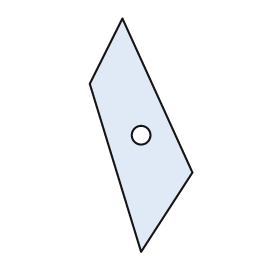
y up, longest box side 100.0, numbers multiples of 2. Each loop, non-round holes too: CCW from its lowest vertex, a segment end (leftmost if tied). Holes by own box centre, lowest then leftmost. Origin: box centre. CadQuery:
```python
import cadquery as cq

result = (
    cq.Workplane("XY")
    .moveTo(0.0, -50.0)
    .lineTo(22.0, -16.0)
    .lineTo(-8.0, 50.0)
    .lineTo(-22.0, 22.0)
    .close()
    .moveTo(0.0, 0.0)
    .circle(4.0)
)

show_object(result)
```